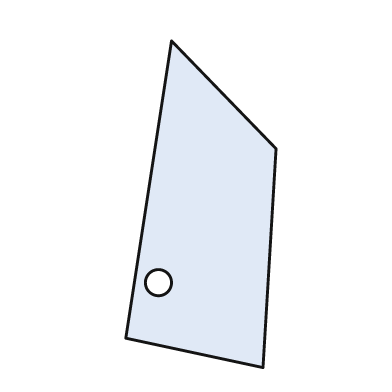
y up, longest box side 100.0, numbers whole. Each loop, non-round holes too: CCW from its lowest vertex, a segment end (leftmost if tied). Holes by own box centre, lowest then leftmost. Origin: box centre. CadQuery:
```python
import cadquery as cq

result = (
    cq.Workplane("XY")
    .moveTo(19.0, -50.0)
    .lineTo(23.0, 17.0)
    .lineTo(-9.0, 50.0)
    .lineTo(-23.0, -41.0)
    .close()
    .moveTo(-13.0, -24.0)
    .circle(4.0)
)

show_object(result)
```